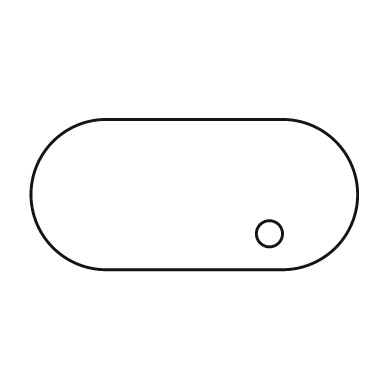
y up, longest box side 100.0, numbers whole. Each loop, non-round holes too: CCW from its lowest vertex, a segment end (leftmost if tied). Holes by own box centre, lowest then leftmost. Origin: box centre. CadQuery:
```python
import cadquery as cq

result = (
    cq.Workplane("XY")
    .moveTo(-27.0, -23.0)
    .lineTo(27.0, -23.0)
    .threePointArc((50.0, 0.0), (27.0, 23.0))
    .lineTo(-27.0, 23.0)
    .threePointArc((-50.0, 0.0), (-27.0, -23.0))
    .close()
    .moveTo(23.0, -12.0)
    .circle(4.0)
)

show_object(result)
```